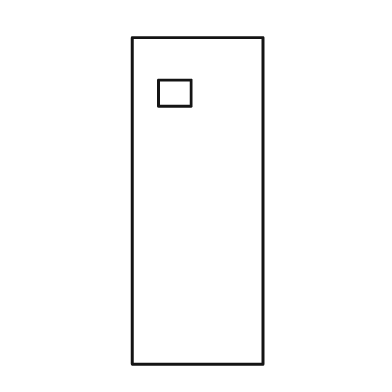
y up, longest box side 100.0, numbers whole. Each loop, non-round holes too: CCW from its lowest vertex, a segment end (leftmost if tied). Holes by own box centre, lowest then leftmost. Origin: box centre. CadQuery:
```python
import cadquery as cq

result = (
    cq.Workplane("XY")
    .moveTo(-20.0, -50.0)
    .lineTo(20.0, -50.0)
    .lineTo(20.0, 50.0)
    .lineTo(-20.0, 50.0)
    .close()
    .moveTo(-12.0, 29.0)
    .lineTo(-2.0, 29.0)
    .lineTo(-2.0, 37.0)
    .lineTo(-12.0, 37.0)
    .close()
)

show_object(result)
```